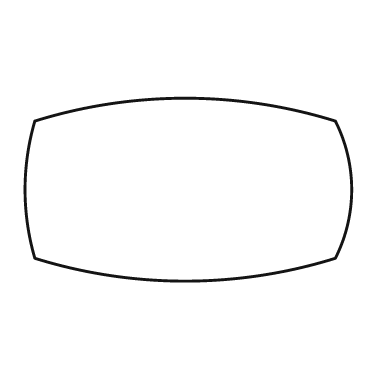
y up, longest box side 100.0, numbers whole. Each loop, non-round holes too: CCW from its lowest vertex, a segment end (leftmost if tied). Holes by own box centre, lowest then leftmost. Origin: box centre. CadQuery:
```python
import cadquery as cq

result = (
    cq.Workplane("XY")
    .moveTo(-47.0, -21.0)
    .threePointArc((-1.0, -28.0), (45.0, -21.0))
    .threePointArc((50.0, 0.0), (45.0, 21.0))
    .threePointArc((-1.0, 28.0), (-47.0, 21.0))
    .threePointArc((-50.0, 0.0), (-47.0, -21.0))
    .close()
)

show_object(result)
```